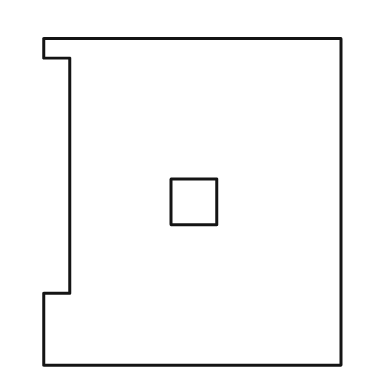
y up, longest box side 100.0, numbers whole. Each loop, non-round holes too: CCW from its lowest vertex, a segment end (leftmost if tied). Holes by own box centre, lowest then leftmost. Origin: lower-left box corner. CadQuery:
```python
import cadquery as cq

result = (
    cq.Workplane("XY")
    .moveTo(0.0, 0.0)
    .lineTo(91.0, 0.0)
    .lineTo(91.0, 100.0)
    .lineTo(0.0, 100.0)
    .lineTo(0.0, 94.0)
    .lineTo(8.0, 94.0)
    .lineTo(8.0, 22.0)
    .lineTo(0.0, 22.0)
    .close()
    .moveTo(39.0, 43.0)
    .lineTo(53.0, 43.0)
    .lineTo(53.0, 57.0)
    .lineTo(39.0, 57.0)
    .close()
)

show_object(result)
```